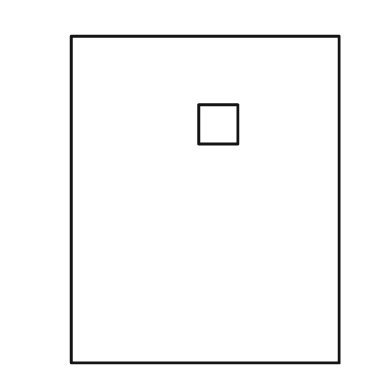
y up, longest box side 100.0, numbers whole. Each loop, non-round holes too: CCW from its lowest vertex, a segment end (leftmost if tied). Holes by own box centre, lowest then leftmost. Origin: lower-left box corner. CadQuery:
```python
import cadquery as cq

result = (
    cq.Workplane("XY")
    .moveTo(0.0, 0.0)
    .lineTo(82.0, 0.0)
    .lineTo(82.0, 100.0)
    .lineTo(0.0, 100.0)
    .close()
    .moveTo(39.0, 67.0)
    .lineTo(51.0, 67.0)
    .lineTo(51.0, 79.0)
    .lineTo(39.0, 79.0)
    .close()
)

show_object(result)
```